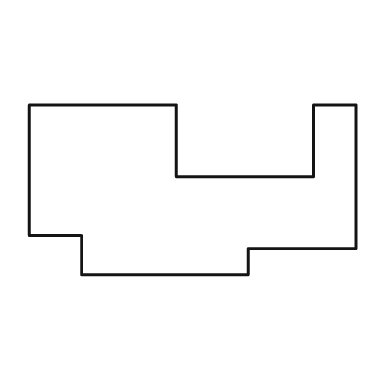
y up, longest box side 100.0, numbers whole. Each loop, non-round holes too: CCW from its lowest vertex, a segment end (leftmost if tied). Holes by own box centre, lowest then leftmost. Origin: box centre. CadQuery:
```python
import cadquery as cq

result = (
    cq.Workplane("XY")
    .moveTo(-34.0, -26.0)
    .lineTo(17.0, -26.0)
    .lineTo(17.0, -18.0)
    .lineTo(50.0, -18.0)
    .lineTo(50.0, 26.0)
    .lineTo(37.0, 26.0)
    .lineTo(37.0, 4.0)
    .lineTo(-5.0, 4.0)
    .lineTo(-5.0, 26.0)
    .lineTo(-50.0, 26.0)
    .lineTo(-50.0, -14.0)
    .lineTo(-34.0, -14.0)
    .close()
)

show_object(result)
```